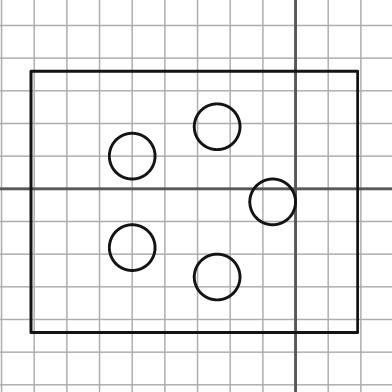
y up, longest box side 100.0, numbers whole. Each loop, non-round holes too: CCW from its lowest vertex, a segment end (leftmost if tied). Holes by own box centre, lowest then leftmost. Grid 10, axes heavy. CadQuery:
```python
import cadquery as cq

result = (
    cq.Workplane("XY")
    .moveTo(-81.0, -44.0)
    .lineTo(19.0, -44.0)
    .lineTo(19.0, 36.0)
    .lineTo(-81.0, 36.0)
    .close()
    .moveTo(-24.0, -27.0)
    .circle(7.0)
    .moveTo(-50.0, -18.0)
    .circle(7.0)
    .moveTo(-7.0, -4.0)
    .circle(7.0)
    .moveTo(-50.0, 10.0)
    .circle(7.0)
    .moveTo(-24.0, 19.0)
    .circle(7.0)
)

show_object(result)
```